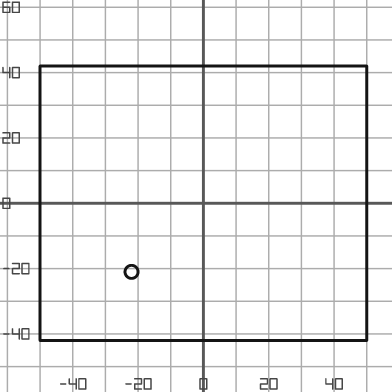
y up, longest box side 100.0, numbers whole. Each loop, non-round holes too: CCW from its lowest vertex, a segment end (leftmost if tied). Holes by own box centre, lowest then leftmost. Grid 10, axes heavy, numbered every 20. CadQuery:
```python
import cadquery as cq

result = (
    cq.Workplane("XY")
    .moveTo(-50.0, -42.0)
    .lineTo(50.0, -42.0)
    .lineTo(50.0, 42.0)
    .lineTo(-50.0, 42.0)
    .close()
    .moveTo(-22.0, -21.0)
    .circle(2.0)
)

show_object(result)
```